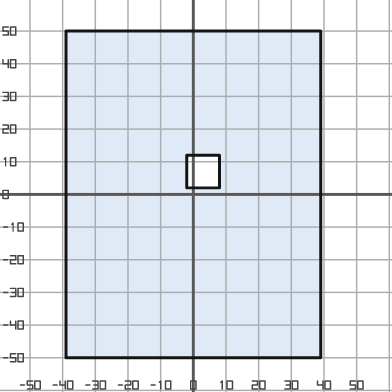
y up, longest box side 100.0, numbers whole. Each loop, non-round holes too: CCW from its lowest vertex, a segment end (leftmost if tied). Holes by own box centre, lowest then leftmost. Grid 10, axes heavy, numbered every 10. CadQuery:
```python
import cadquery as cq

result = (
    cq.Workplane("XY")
    .moveTo(-39.0, -50.0)
    .lineTo(39.0, -50.0)
    .lineTo(39.0, 50.0)
    .lineTo(-39.0, 50.0)
    .close()
    .moveTo(-2.0, 2.0)
    .lineTo(8.0, 2.0)
    .lineTo(8.0, 12.0)
    .lineTo(-2.0, 12.0)
    .close()
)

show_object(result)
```